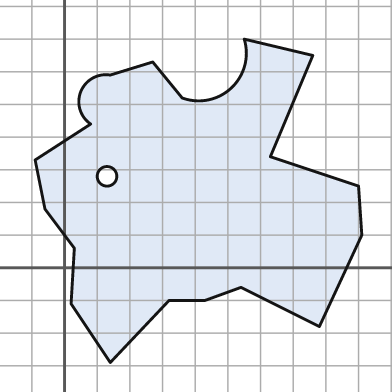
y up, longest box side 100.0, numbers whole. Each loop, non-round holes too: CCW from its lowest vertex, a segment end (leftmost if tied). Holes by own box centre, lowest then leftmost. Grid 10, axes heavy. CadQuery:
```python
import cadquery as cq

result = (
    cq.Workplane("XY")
    .moveTo(14.0, -29.0)
    .lineTo(32.0, -10.0)
    .lineTo(43.0, -10.0)
    .lineTo(54.0, -6.0)
    .lineTo(78.0, -18.0)
    .lineTo(91.0, 10.0)
    .lineTo(90.0, 25.0)
    .lineTo(63.0, 34.0)
    .lineTo(76.0, 65.0)
    .lineTo(55.0, 70.0)
    .threePointArc((51.0, 55.0), (36.0, 52.0))
    .lineTo(27.0, 63.0)
    .lineTo(14.0, 59.0)
    .threePointArc((5.0, 54.0), (8.0, 44.0))
    .lineTo(-9.0, 33.0)
    .lineTo(-6.0, 18.0)
    .lineTo(3.0, 6.0)
    .lineTo(2.0, -11.0)
    .close()
    .moveTo(13.0, 28.0)
    .circle(3.0)
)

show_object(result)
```